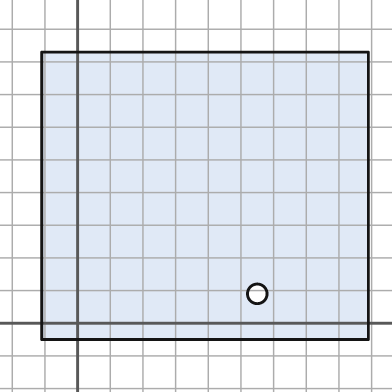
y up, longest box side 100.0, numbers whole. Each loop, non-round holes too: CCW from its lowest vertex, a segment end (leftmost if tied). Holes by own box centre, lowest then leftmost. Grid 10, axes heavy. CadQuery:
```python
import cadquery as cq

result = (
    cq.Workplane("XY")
    .moveTo(-11.0, -5.0)
    .lineTo(89.0, -5.0)
    .lineTo(89.0, 83.0)
    .lineTo(-11.0, 83.0)
    .close()
    .moveTo(55.0, 9.0)
    .circle(3.0)
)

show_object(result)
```